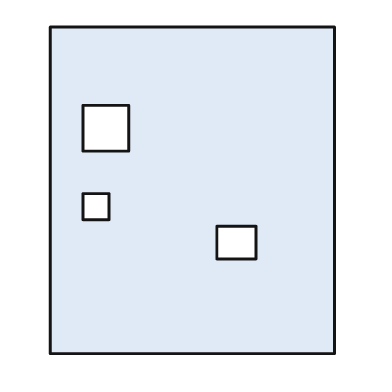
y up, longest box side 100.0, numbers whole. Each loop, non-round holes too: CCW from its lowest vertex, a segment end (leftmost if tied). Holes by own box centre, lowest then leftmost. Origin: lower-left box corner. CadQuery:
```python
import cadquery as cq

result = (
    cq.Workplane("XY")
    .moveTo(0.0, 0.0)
    .lineTo(87.0, 0.0)
    .lineTo(87.0, 100.0)
    .lineTo(0.0, 100.0)
    .close()
    .moveTo(51.0, 29.0)
    .lineTo(63.0, 29.0)
    .lineTo(63.0, 39.0)
    .lineTo(51.0, 39.0)
    .close()
    .moveTo(10.0, 41.0)
    .lineTo(18.0, 41.0)
    .lineTo(18.0, 49.0)
    .lineTo(10.0, 49.0)
    .close()
    .moveTo(10.0, 62.0)
    .lineTo(24.0, 62.0)
    .lineTo(24.0, 76.0)
    .lineTo(10.0, 76.0)
    .close()
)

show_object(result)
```